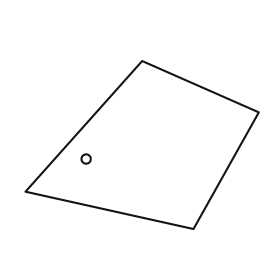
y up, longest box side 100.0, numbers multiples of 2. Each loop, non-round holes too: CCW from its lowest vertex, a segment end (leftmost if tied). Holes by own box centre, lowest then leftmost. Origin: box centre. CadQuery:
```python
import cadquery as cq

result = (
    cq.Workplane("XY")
    .moveTo(22.0, -36.0)
    .lineTo(50.0, 14.0)
    .lineTo(0.0, 36.0)
    .lineTo(-50.0, -20.0)
    .close()
    .moveTo(-24.0, -6.0)
    .circle(2.0)
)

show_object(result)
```